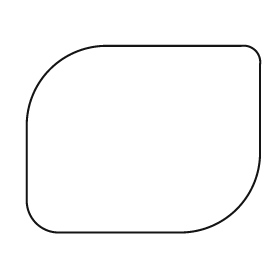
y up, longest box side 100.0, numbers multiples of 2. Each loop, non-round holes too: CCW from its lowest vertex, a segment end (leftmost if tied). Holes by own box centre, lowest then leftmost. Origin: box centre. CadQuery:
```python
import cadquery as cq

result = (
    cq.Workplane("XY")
    .moveTo(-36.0, -40.0)
    .lineTo(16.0, -40.0)
    .threePointArc((40.0, -30.0), (50.0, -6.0))
    .lineTo(50.0, 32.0)
    .threePointArc((48.0, 38.0), (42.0, 40.0))
    .lineTo(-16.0, 40.0)
    .threePointArc((-40.0, 30.0), (-50.0, 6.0))
    .lineTo(-50.0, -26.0)
    .threePointArc((-46.0, -36.0), (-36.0, -40.0))
    .close()
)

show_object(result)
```